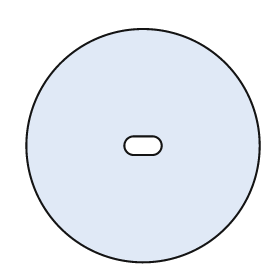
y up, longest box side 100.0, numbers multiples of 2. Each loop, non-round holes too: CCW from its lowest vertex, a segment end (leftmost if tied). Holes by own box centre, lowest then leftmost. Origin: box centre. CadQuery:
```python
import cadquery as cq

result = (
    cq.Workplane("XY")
    .moveTo(0.0, 0.0)
    .circle(50.0)
    .moveTo(-4.0, -4.0)
    .lineTo(4.0, -4.0)
    .threePointArc((8.0, 0.0), (4.0, 4.0))
    .lineTo(-4.0, 4.0)
    .threePointArc((-8.0, 0.0), (-4.0, -4.0))
    .close()
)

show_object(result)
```